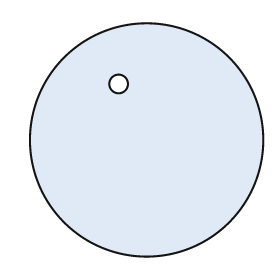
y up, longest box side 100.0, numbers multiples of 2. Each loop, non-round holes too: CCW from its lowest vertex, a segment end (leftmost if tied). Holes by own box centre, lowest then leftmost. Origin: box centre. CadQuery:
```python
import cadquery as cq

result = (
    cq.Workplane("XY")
    .moveTo(0.0, 0.0)
    .circle(50.0)
    .moveTo(-12.0, 24.0)
    .circle(4.0)
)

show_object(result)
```